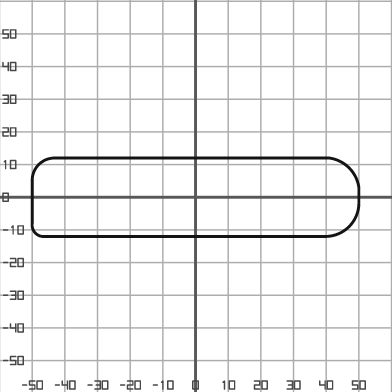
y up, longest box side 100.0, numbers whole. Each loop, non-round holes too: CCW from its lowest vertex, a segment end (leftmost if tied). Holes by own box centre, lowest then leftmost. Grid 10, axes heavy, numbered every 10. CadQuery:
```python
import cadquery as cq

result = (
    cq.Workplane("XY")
    .moveTo(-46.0, -12.0)
    .lineTo(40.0, -12.0)
    .threePointArc((47.0, -9.0), (50.0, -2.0))
    .lineTo(50.0, 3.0)
    .threePointArc((47.0, 9.0), (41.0, 12.0))
    .lineTo(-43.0, 12.0)
    .threePointArc((-48.0, 10.0), (-50.0, 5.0))
    .lineTo(-50.0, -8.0)
    .threePointArc((-49.0, -11.0), (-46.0, -12.0))
    .close()
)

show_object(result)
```